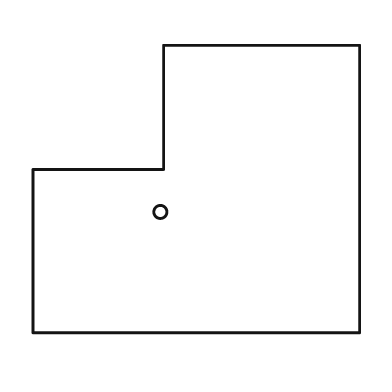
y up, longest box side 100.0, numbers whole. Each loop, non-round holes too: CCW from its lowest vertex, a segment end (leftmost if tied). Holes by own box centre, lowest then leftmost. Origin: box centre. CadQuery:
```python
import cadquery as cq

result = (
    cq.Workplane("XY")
    .moveTo(-50.0, -44.0)
    .lineTo(50.0, -44.0)
    .lineTo(50.0, 44.0)
    .lineTo(-10.0, 44.0)
    .lineTo(-10.0, 6.0)
    .lineTo(-50.0, 6.0)
    .close()
    .moveTo(-11.0, -7.0)
    .circle(2.0)
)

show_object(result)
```